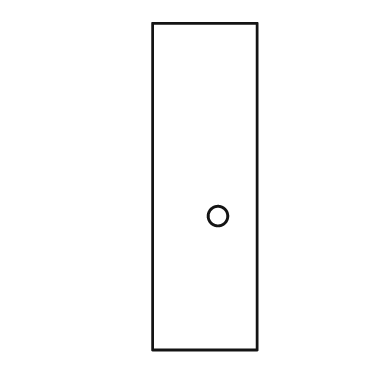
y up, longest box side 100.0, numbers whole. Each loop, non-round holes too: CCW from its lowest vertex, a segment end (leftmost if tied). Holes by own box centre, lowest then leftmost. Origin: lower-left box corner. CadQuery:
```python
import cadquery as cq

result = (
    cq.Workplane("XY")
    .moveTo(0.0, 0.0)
    .lineTo(32.0, 0.0)
    .lineTo(32.0, 100.0)
    .lineTo(0.0, 100.0)
    .close()
    .moveTo(20.0, 41.0)
    .circle(3.0)
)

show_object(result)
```